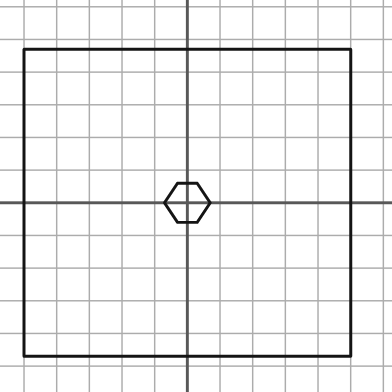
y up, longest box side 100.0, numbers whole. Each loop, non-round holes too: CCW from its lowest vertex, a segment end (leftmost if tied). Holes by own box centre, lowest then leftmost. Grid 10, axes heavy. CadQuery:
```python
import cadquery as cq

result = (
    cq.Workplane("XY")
    .moveTo(-50.0, -47.0)
    .lineTo(50.0, -47.0)
    .lineTo(50.0, 47.0)
    .lineTo(-50.0, 47.0)
    .close()
    .moveTo(-3.0, -6.0)
    .lineTo(3.0, -6.0)
    .lineTo(7.0, 0.0)
    .lineTo(3.0, 6.0)
    .lineTo(-3.0, 6.0)
    .lineTo(-7.0, 0.0)
    .close()
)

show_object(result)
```